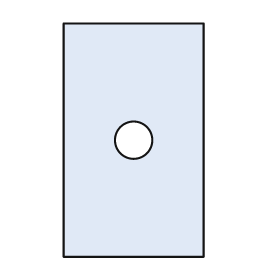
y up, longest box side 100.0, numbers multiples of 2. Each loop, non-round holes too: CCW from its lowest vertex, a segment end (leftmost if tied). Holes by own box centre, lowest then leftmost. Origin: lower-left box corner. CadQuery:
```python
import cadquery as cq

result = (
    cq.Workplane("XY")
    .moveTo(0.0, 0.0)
    .lineTo(60.0, 0.0)
    .lineTo(60.0, 100.0)
    .lineTo(0.0, 100.0)
    .close()
    .moveTo(30.0, 50.0)
    .circle(8.0)
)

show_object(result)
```